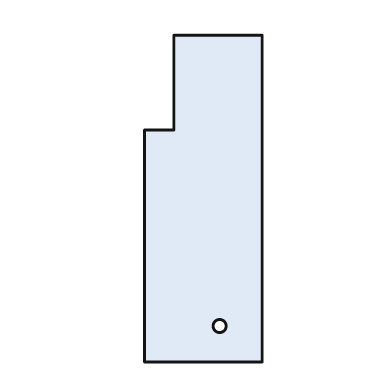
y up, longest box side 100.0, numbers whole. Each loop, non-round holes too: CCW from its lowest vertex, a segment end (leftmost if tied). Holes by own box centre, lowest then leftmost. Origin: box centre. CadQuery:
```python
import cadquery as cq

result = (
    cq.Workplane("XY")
    .moveTo(-18.0, -50.0)
    .lineTo(18.0, -50.0)
    .lineTo(18.0, 50.0)
    .lineTo(-9.0, 50.0)
    .lineTo(-9.0, 21.0)
    .lineTo(-18.0, 21.0)
    .close()
    .moveTo(5.0, -39.0)
    .circle(2.0)
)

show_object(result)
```